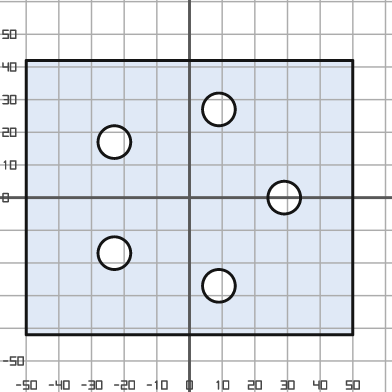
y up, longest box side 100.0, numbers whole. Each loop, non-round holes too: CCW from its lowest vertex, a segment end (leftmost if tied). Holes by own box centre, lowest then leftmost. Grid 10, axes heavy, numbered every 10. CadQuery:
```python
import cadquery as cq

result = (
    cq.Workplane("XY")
    .moveTo(-50.0, -42.0)
    .lineTo(50.0, -42.0)
    .lineTo(50.0, 42.0)
    .lineTo(-50.0, 42.0)
    .close()
    .moveTo(9.0, -27.0)
    .circle(5.0)
    .moveTo(-23.0, -17.0)
    .circle(5.0)
    .moveTo(29.0, 0.0)
    .circle(5.0)
    .moveTo(-23.0, 17.0)
    .circle(5.0)
    .moveTo(9.0, 27.0)
    .circle(5.0)
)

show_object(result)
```